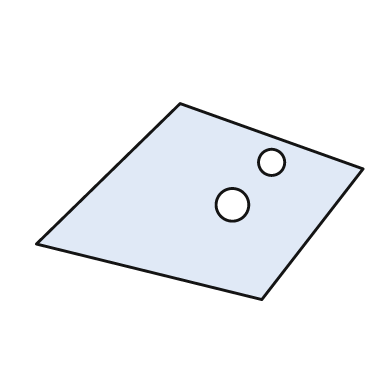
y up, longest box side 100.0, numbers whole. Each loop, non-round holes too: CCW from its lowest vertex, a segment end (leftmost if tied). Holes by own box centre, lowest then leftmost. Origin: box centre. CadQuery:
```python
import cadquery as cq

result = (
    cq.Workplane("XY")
    .moveTo(19.0, -30.0)
    .lineTo(50.0, 10.0)
    .lineTo(-6.0, 30.0)
    .lineTo(-50.0, -13.0)
    .close()
    .moveTo(10.0, -1.0)
    .circle(5.0)
    .moveTo(22.0, 12.0)
    .circle(4.0)
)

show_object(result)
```